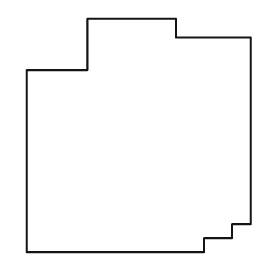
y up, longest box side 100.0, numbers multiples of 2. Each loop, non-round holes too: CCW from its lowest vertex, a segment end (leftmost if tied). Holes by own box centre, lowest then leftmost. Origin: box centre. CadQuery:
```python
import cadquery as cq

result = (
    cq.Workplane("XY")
    .moveTo(-48.0, -50.0)
    .lineTo(28.0, -50.0)
    .lineTo(28.0, -44.0)
    .lineTo(40.0, -44.0)
    .lineTo(40.0, -38.0)
    .lineTo(48.0, -38.0)
    .lineTo(48.0, 42.0)
    .lineTo(16.0, 42.0)
    .lineTo(16.0, 50.0)
    .lineTo(-22.0, 50.0)
    .lineTo(-22.0, 28.0)
    .lineTo(-48.0, 28.0)
    .close()
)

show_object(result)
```